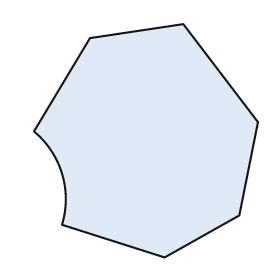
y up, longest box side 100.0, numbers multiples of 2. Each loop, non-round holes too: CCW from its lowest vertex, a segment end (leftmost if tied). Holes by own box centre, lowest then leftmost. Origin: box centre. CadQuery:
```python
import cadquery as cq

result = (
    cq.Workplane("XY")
    .moveTo(8.0, -50.0)
    .lineTo(40.0, -32.0)
    .lineTo(48.0, 8.0)
    .lineTo(16.0, 50.0)
    .lineTo(-24.0, 44.0)
    .lineTo(-48.0, 4.0)
    .threePointArc((-36.0, -14.0), (-36.0, -36.0))
    .close()
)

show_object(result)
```